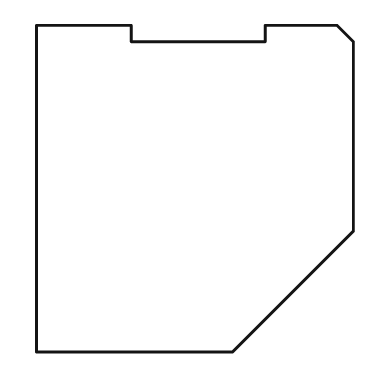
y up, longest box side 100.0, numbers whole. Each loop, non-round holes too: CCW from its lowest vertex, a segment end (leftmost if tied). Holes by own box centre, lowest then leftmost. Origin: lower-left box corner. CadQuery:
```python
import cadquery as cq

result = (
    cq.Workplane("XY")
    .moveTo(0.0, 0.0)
    .lineTo(60.0, 0.0)
    .lineTo(97.0, 37.0)
    .lineTo(97.0, 95.0)
    .lineTo(92.0, 100.0)
    .lineTo(70.0, 100.0)
    .lineTo(70.0, 95.0)
    .lineTo(29.0, 95.0)
    .lineTo(29.0, 100.0)
    .lineTo(0.0, 100.0)
    .close()
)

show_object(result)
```